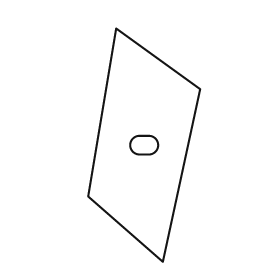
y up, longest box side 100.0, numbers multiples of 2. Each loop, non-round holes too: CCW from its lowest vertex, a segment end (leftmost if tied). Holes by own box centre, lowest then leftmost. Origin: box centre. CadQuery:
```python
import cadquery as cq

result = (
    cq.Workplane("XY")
    .moveTo(8.0, -50.0)
    .lineTo(24.0, 24.0)
    .lineTo(-12.0, 50.0)
    .lineTo(-24.0, -22.0)
    .close()
    .moveTo(-2.0, -4.0)
    .lineTo(2.0, -4.0)
    .threePointArc((6.0, 0.0), (2.0, 4.0))
    .lineTo(-2.0, 4.0)
    .threePointArc((-6.0, 0.0), (-2.0, -4.0))
    .close()
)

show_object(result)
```